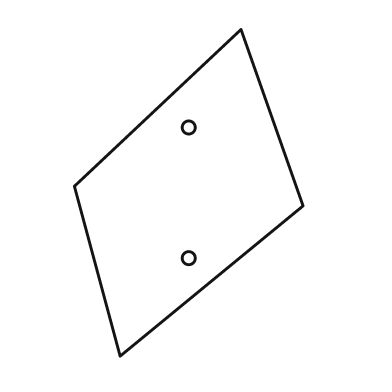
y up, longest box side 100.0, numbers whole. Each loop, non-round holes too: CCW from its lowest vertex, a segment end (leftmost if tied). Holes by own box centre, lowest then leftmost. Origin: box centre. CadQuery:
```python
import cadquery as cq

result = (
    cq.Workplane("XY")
    .moveTo(-21.0, -50.0)
    .lineTo(35.0, -4.0)
    .lineTo(16.0, 50.0)
    .lineTo(-35.0, 2.0)
    .close()
    .moveTo(0.0, -20.0)
    .circle(2.0)
    .moveTo(0.0, 20.0)
    .circle(2.0)
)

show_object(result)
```